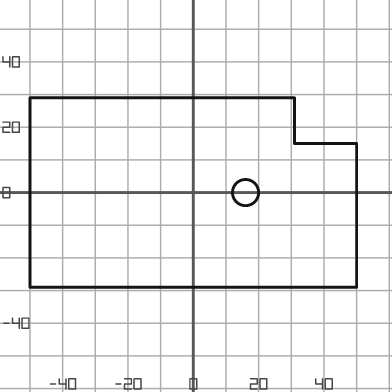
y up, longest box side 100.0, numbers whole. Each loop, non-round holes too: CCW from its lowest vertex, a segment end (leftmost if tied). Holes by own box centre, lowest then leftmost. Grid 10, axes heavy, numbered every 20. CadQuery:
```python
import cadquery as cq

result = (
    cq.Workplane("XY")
    .moveTo(-50.0, -29.0)
    .lineTo(50.0, -29.0)
    .lineTo(50.0, 15.0)
    .lineTo(31.0, 15.0)
    .lineTo(31.0, 29.0)
    .lineTo(-50.0, 29.0)
    .close()
    .moveTo(16.0, 0.0)
    .circle(4.0)
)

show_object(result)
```